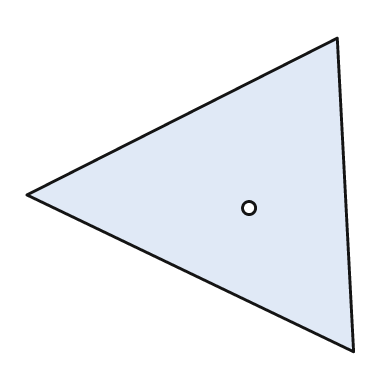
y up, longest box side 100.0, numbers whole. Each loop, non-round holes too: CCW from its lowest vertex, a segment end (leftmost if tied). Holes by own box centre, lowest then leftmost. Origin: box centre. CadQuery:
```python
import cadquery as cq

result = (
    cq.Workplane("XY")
    .moveTo(50.0, -48.0)
    .lineTo(45.0, 48.0)
    .lineTo(-50.0, 0.0)
    .close()
    .moveTo(18.0, -4.0)
    .circle(2.0)
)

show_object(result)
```